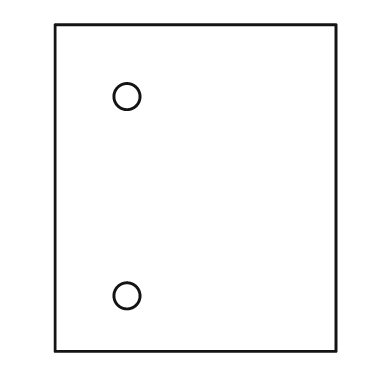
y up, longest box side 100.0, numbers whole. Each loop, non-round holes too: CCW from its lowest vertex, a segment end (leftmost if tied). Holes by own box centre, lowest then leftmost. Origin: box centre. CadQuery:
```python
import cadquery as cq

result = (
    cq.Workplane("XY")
    .moveTo(-43.0, -50.0)
    .lineTo(43.0, -50.0)
    .lineTo(43.0, 50.0)
    .lineTo(-43.0, 50.0)
    .close()
    .moveTo(-21.0, -33.0)
    .circle(4.0)
    .moveTo(-21.0, 28.0)
    .circle(4.0)
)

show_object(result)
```